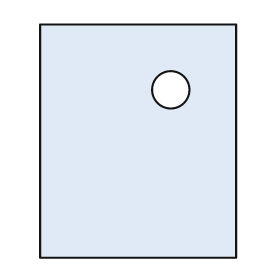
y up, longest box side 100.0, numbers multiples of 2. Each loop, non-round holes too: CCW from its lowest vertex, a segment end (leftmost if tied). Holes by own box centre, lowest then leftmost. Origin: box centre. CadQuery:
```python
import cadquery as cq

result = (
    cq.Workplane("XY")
    .moveTo(-42.0, -50.0)
    .lineTo(42.0, -50.0)
    .lineTo(42.0, 50.0)
    .lineTo(-42.0, 50.0)
    .close()
    .moveTo(14.0, 22.0)
    .circle(8.0)
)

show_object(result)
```